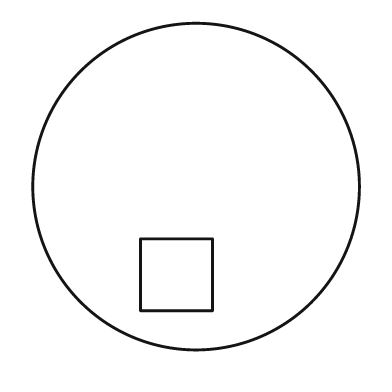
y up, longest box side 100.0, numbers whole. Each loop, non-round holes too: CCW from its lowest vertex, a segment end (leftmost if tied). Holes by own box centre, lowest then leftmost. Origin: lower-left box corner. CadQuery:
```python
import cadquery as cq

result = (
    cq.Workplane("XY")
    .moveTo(50.0, 50.0)
    .circle(50.0)
    .moveTo(33.0, 12.0)
    .lineTo(55.0, 12.0)
    .lineTo(55.0, 34.0)
    .lineTo(33.0, 34.0)
    .close()
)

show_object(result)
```